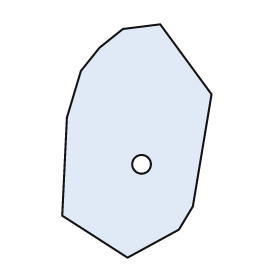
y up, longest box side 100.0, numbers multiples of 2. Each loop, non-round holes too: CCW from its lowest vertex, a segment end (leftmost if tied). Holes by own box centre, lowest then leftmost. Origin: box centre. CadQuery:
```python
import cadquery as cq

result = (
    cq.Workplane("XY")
    .moveTo(-4.0, -50.0)
    .lineTo(18.0, -38.0)
    .lineTo(24.0, -28.0)
    .lineTo(32.0, 20.0)
    .lineTo(10.0, 50.0)
    .lineTo(-6.0, 48.0)
    .lineTo(-16.0, 40.0)
    .lineTo(-24.0, 30.0)
    .lineTo(-30.0, 10.0)
    .lineTo(-32.0, -32.0)
    .close()
    .moveTo(2.0, -10.0)
    .circle(4.0)
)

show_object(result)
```